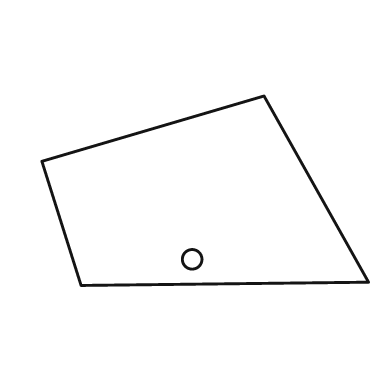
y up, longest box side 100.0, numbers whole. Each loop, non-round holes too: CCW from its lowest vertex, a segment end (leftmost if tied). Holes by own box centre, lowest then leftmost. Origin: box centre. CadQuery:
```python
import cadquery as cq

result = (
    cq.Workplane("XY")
    .moveTo(-38.0, -29.0)
    .lineTo(50.0, -28.0)
    .lineTo(18.0, 29.0)
    .lineTo(-50.0, 9.0)
    .close()
    .moveTo(-4.0, -21.0)
    .circle(3.0)
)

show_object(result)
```